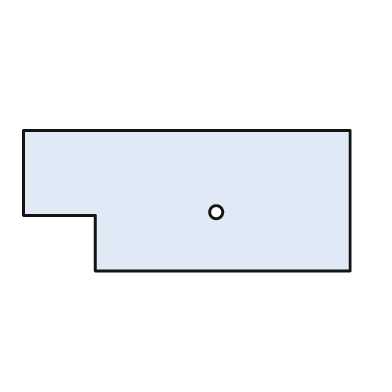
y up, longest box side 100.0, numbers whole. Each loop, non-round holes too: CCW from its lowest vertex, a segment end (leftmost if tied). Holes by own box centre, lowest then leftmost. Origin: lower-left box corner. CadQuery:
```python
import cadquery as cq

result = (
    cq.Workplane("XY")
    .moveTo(22.0, 0.0)
    .lineTo(100.0, 0.0)
    .lineTo(100.0, 43.0)
    .lineTo(0.0, 43.0)
    .lineTo(0.0, 17.0)
    .lineTo(22.0, 17.0)
    .close()
    .moveTo(59.0, 18.0)
    .circle(2.0)
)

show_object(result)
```